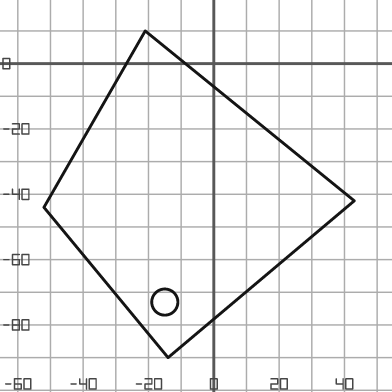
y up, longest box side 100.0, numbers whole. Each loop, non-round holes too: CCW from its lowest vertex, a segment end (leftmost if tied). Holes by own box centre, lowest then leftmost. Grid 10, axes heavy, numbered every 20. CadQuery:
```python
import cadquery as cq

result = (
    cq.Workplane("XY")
    .moveTo(-14.0, -90.0)
    .lineTo(43.0, -42.0)
    .lineTo(-21.0, 10.0)
    .lineTo(-52.0, -44.0)
    .close()
    .moveTo(-15.0, -73.0)
    .circle(4.0)
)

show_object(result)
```